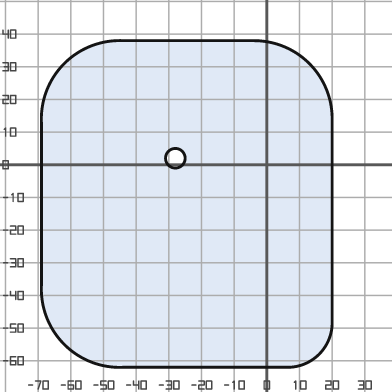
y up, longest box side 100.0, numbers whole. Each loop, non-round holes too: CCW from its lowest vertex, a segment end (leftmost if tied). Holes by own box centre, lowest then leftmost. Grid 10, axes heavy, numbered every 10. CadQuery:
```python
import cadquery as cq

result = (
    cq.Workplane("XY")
    .moveTo(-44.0, -62.0)
    .lineTo(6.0, -62.0)
    .threePointArc((16.0, -58.0), (20.0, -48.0))
    .lineTo(20.0, 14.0)
    .threePointArc((13.0, 31.0), (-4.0, 38.0))
    .lineTo(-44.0, 38.0)
    .threePointArc((-62.0, 31.0), (-69.0, 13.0))
    .lineTo(-69.0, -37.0)
    .threePointArc((-62.0, -55.0), (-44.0, -62.0))
    .close()
    .moveTo(-28.0, 2.0)
    .circle(3.0)
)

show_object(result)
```